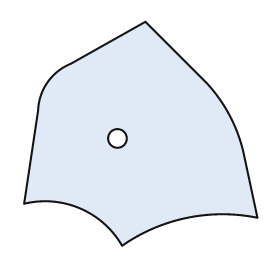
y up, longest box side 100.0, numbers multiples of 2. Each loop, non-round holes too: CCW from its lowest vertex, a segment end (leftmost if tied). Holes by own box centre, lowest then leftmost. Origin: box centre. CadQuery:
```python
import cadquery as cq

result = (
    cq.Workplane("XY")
    .moveTo(-8.0, -48.0)
    .threePointArc((20.0, -36.0), (50.0, -36.0))
    .lineTo(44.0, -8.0)
    .threePointArc((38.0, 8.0), (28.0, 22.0))
    .lineTo(2.0, 48.0)
    .lineTo(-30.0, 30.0)
    .threePointArc((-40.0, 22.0), (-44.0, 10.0))
    .lineTo(-50.0, -30.0)
    .threePointArc((-26.0, -32.0), (-8.0, -48.0))
    .close()
    .moveTo(-10.0, -2.0)
    .circle(4.0)
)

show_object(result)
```